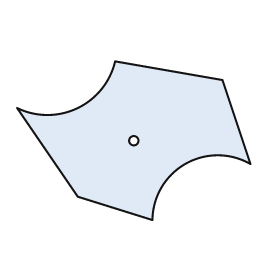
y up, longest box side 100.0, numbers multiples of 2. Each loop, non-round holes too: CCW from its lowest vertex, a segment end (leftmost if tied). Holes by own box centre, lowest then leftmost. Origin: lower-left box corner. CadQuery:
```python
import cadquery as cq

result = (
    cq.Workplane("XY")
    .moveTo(58.0, 0.0)
    .threePointArc((72.0, 24.0), (100.0, 24.0))
    .lineTo(88.0, 60.0)
    .lineTo(42.0, 68.0)
    .threePointArc((26.0, 48.0), (0.0, 48.0))
    .lineTo(26.0, 10.0)
    .close()
    .moveTo(50.0, 34.0)
    .circle(2.0)
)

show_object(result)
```